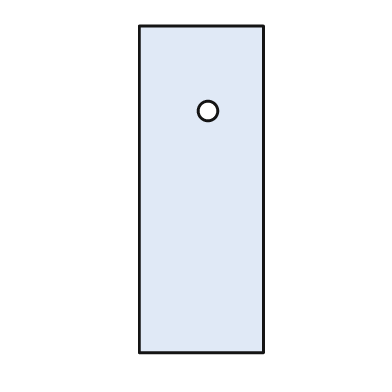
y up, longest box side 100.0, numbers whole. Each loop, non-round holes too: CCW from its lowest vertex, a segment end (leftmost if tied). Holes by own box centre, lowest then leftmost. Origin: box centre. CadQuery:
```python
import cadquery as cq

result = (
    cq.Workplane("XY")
    .moveTo(-19.0, -50.0)
    .lineTo(19.0, -50.0)
    .lineTo(19.0, 50.0)
    .lineTo(-19.0, 50.0)
    .close()
    .moveTo(2.0, 24.0)
    .circle(3.0)
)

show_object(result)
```